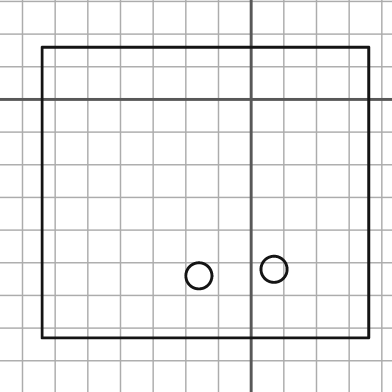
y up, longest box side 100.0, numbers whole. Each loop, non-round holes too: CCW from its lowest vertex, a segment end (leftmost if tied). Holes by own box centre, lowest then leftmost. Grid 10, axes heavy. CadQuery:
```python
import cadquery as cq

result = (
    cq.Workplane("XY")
    .moveTo(-64.0, -73.0)
    .lineTo(36.0, -73.0)
    .lineTo(36.0, 16.0)
    .lineTo(-64.0, 16.0)
    .close()
    .moveTo(-16.0, -54.0)
    .circle(4.0)
    .moveTo(7.0, -52.0)
    .circle(4.0)
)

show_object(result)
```